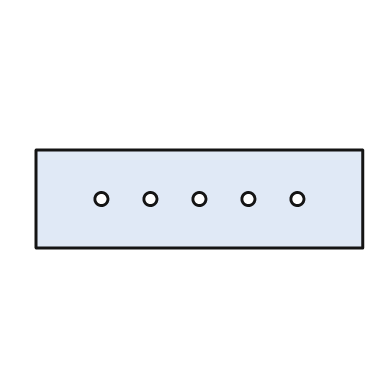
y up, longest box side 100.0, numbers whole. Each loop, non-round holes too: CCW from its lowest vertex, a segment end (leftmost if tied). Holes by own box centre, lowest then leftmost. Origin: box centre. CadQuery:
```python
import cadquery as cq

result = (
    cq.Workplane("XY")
    .moveTo(-50.0, -15.0)
    .lineTo(50.0, -15.0)
    .lineTo(50.0, 15.0)
    .lineTo(-50.0, 15.0)
    .close()
    .moveTo(-30.0, 0.0)
    .circle(2.0)
    .moveTo(-15.0, 0.0)
    .circle(2.0)
    .moveTo(0.0, 0.0)
    .circle(2.0)
    .moveTo(15.0, 0.0)
    .circle(2.0)
    .moveTo(30.0, 0.0)
    .circle(2.0)
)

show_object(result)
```